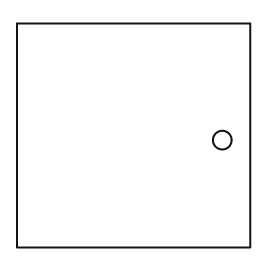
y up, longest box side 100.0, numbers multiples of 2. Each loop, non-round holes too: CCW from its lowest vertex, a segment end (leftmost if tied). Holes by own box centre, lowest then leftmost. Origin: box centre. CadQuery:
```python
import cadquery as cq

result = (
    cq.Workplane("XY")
    .moveTo(-50.0, -48.0)
    .lineTo(50.0, -48.0)
    .lineTo(50.0, 48.0)
    .lineTo(-50.0, 48.0)
    .close()
    .moveTo(38.0, -2.0)
    .circle(4.0)
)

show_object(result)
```